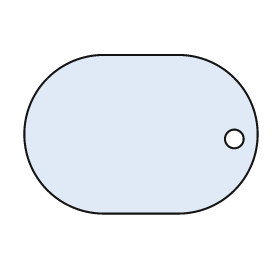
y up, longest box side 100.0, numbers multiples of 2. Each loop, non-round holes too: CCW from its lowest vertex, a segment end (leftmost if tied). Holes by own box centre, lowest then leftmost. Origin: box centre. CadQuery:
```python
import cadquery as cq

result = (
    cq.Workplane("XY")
    .moveTo(-16.0, -34.0)
    .lineTo(16.0, -34.0)
    .threePointArc((50.0, 0.0), (16.0, 34.0))
    .lineTo(-16.0, 34.0)
    .threePointArc((-50.0, 0.0), (-16.0, -34.0))
    .close()
    .moveTo(40.0, -2.0)
    .circle(4.0)
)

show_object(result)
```